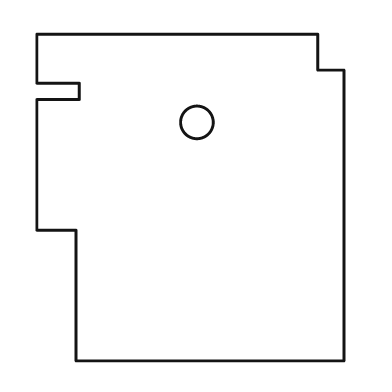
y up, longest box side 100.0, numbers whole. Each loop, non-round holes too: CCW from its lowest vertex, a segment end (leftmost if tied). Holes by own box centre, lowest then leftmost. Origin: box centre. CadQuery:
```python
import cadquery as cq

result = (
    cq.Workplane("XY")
    .moveTo(-35.0, -50.0)
    .lineTo(47.0, -50.0)
    .lineTo(47.0, 39.0)
    .lineTo(39.0, 39.0)
    .lineTo(39.0, 50.0)
    .lineTo(-47.0, 50.0)
    .lineTo(-47.0, 35.0)
    .lineTo(-34.0, 35.0)
    .lineTo(-34.0, 30.0)
    .lineTo(-47.0, 30.0)
    .lineTo(-47.0, -10.0)
    .lineTo(-35.0, -10.0)
    .close()
    .moveTo(2.0, 23.0)
    .circle(5.0)
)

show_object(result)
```